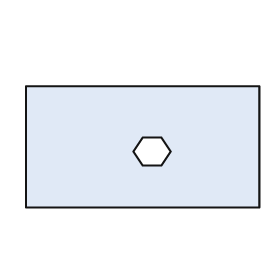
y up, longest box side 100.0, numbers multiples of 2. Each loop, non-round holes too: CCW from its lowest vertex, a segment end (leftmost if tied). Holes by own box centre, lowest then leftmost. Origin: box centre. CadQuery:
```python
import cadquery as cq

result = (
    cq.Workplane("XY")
    .moveTo(-50.0, -26.0)
    .lineTo(50.0, -26.0)
    .lineTo(50.0, 26.0)
    .lineTo(-50.0, 26.0)
    .close()
    .moveTo(0.0, -8.0)
    .lineTo(8.0, -8.0)
    .lineTo(12.0, -2.0)
    .lineTo(8.0, 4.0)
    .lineTo(0.0, 4.0)
    .lineTo(-4.0, -2.0)
    .close()
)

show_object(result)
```